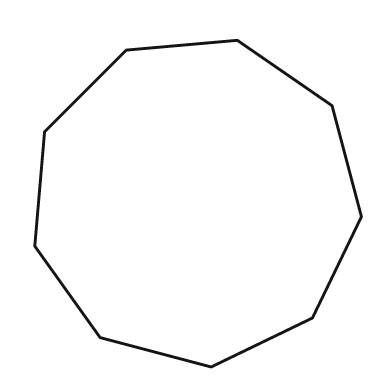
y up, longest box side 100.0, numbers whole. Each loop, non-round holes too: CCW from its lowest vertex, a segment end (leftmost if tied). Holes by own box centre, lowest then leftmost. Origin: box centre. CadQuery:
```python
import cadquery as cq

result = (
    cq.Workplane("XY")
    .moveTo(4.0, -50.0)
    .lineTo(35.0, -35.0)
    .lineTo(50.0, -4.0)
    .lineTo(41.0, 30.0)
    .lineTo(12.0, 50.0)
    .lineTo(-22.0, 47.0)
    .lineTo(-47.0, 22.0)
    .lineTo(-50.0, -13.0)
    .lineTo(-30.0, -41.0)
    .close()
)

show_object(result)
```